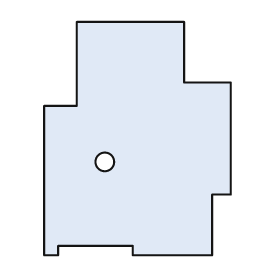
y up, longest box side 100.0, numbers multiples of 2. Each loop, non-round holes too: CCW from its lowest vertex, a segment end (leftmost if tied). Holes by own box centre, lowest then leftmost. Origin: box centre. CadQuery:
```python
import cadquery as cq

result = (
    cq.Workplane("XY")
    .moveTo(-40.0, -50.0)
    .lineTo(-34.0, -50.0)
    .lineTo(-34.0, -46.0)
    .lineTo(-2.0, -46.0)
    .lineTo(-2.0, -50.0)
    .lineTo(32.0, -50.0)
    .lineTo(32.0, -24.0)
    .lineTo(40.0, -24.0)
    .lineTo(40.0, 24.0)
    .lineTo(20.0, 24.0)
    .lineTo(20.0, 50.0)
    .lineTo(-26.0, 50.0)
    .lineTo(-26.0, 14.0)
    .lineTo(-40.0, 14.0)
    .close()
    .moveTo(-14.0, -10.0)
    .circle(4.0)
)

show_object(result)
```